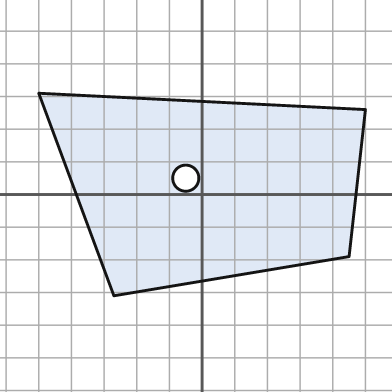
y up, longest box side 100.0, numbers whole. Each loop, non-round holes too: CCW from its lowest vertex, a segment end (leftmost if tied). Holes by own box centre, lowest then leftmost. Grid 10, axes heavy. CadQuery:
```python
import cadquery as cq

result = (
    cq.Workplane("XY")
    .moveTo(-27.0, -31.0)
    .lineTo(45.0, -19.0)
    .lineTo(50.0, 26.0)
    .lineTo(-50.0, 31.0)
    .close()
    .moveTo(-5.0, 5.0)
    .circle(4.0)
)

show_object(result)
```